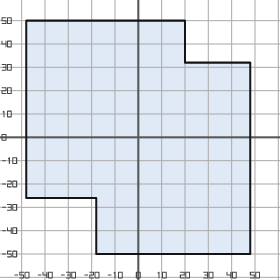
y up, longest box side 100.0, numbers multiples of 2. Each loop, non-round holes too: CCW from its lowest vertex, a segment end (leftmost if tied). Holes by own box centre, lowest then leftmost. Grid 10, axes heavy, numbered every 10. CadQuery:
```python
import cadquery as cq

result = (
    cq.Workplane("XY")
    .moveTo(-18.0, -50.0)
    .lineTo(48.0, -50.0)
    .lineTo(48.0, 32.0)
    .lineTo(20.0, 32.0)
    .lineTo(20.0, 50.0)
    .lineTo(-48.0, 50.0)
    .lineTo(-48.0, -26.0)
    .lineTo(-18.0, -26.0)
    .close()
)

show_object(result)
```